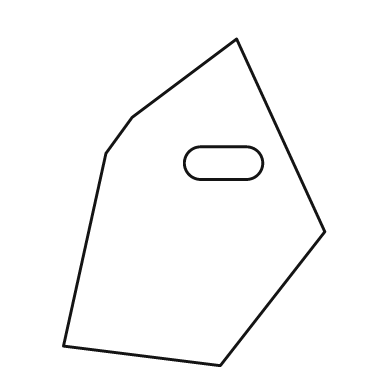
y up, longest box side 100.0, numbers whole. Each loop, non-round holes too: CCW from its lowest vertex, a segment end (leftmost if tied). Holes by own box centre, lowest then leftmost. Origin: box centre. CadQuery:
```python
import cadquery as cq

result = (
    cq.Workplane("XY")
    .moveTo(8.0, -50.0)
    .lineTo(40.0, -9.0)
    .lineTo(13.0, 50.0)
    .lineTo(-19.0, 26.0)
    .lineTo(-27.0, 15.0)
    .lineTo(-40.0, -44.0)
    .close()
    .moveTo(2.0, 7.0)
    .lineTo(16.0, 7.0)
    .threePointArc((21.0, 12.0), (16.0, 17.0))
    .lineTo(2.0, 17.0)
    .threePointArc((-3.0, 12.0), (2.0, 7.0))
    .close()
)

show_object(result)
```